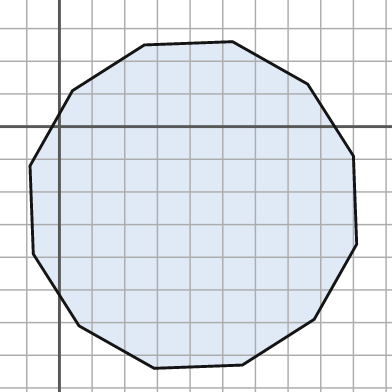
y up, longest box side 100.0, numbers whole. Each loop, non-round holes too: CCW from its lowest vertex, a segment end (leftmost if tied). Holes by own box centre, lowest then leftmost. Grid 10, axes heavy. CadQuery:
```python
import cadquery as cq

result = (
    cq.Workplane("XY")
    .moveTo(29.0, -74.0)
    .lineTo(56.0, -73.0)
    .lineTo(78.0, -59.0)
    .lineTo(91.0, -36.0)
    .lineTo(90.0, -9.0)
    .lineTo(76.0, 13.0)
    .lineTo(53.0, 26.0)
    .lineTo(26.0, 25.0)
    .lineTo(4.0, 11.0)
    .lineTo(-9.0, -12.0)
    .lineTo(-8.0, -39.0)
    .lineTo(6.0, -61.0)
    .close()
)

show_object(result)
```